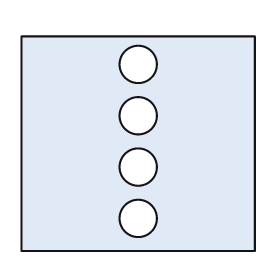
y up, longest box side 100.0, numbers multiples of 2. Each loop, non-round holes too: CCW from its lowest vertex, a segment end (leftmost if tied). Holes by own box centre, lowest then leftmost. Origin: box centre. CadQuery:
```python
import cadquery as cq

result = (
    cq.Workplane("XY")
    .moveTo(-50.0, -46.0)
    .lineTo(50.0, -46.0)
    .lineTo(50.0, 46.0)
    .lineTo(-50.0, 46.0)
    .close()
    .moveTo(0.0, -32.0)
    .circle(8.0)
    .moveTo(0.0, -10.0)
    .circle(8.0)
    .moveTo(0.0, 12.0)
    .circle(8.0)
    .moveTo(0.0, 34.0)
    .circle(8.0)
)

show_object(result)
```